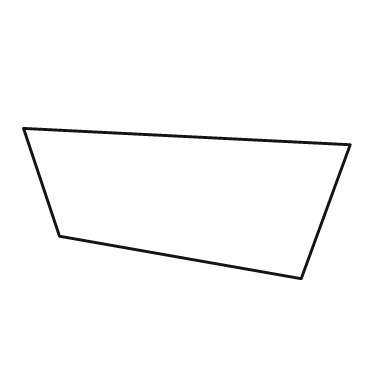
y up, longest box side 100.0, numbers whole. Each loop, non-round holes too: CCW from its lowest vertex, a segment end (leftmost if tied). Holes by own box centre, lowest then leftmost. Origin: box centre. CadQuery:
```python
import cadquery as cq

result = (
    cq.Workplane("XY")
    .moveTo(35.0, -23.0)
    .lineTo(50.0, 18.0)
    .lineTo(-50.0, 23.0)
    .lineTo(-39.0, -10.0)
    .close()
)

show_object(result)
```